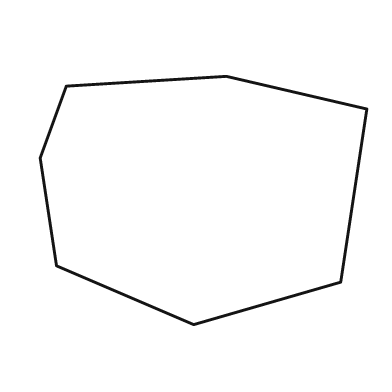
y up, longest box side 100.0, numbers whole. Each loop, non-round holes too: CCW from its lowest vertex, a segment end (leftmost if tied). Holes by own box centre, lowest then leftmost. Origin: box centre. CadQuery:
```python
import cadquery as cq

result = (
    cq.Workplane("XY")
    .moveTo(-3.0, -38.0)
    .lineTo(42.0, -25.0)
    .lineTo(50.0, 28.0)
    .lineTo(7.0, 38.0)
    .lineTo(-42.0, 35.0)
    .lineTo(-50.0, 13.0)
    .lineTo(-45.0, -20.0)
    .close()
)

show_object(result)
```